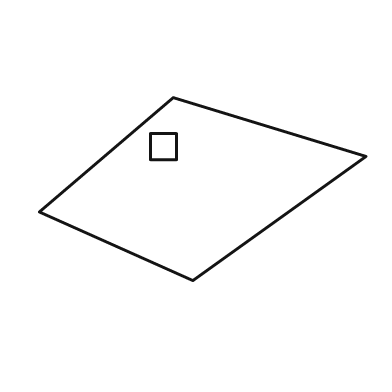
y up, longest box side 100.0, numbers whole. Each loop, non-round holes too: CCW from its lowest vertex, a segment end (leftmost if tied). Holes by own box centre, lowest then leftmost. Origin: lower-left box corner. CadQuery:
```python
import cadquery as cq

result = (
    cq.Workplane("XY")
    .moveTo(47.0, 0.0)
    .lineTo(100.0, 38.0)
    .lineTo(41.0, 56.0)
    .lineTo(0.0, 21.0)
    .close()
    .moveTo(34.0, 37.0)
    .lineTo(42.0, 37.0)
    .lineTo(42.0, 45.0)
    .lineTo(34.0, 45.0)
    .close()
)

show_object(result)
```